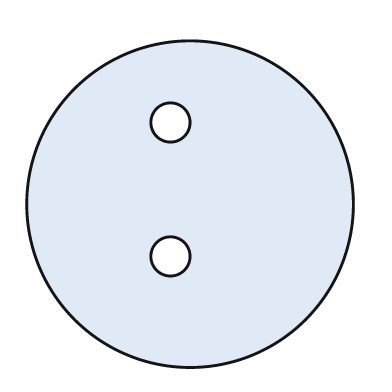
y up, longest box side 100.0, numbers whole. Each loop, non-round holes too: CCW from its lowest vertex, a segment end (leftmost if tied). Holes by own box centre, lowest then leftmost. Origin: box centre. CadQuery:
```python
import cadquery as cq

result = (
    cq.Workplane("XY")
    .moveTo(0.0, 0.0)
    .circle(50.0)
    .moveTo(-6.0, -16.0)
    .circle(6.0)
    .moveTo(-6.0, 25.0)
    .circle(6.0)
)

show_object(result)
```